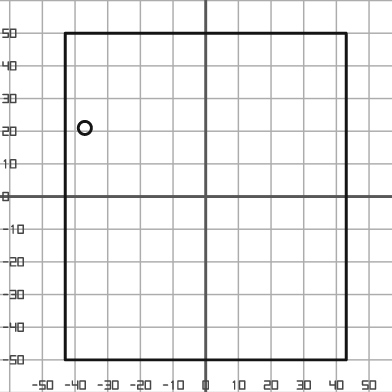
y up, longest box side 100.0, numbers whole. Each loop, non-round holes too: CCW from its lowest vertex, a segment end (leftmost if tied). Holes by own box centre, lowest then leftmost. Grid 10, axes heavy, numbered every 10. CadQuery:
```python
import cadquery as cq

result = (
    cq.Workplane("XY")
    .moveTo(-43.0, -50.0)
    .lineTo(43.0, -50.0)
    .lineTo(43.0, 50.0)
    .lineTo(-43.0, 50.0)
    .close()
    .moveTo(-37.0, 21.0)
    .circle(2.0)
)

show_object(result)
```